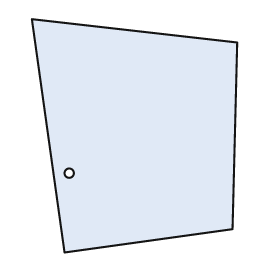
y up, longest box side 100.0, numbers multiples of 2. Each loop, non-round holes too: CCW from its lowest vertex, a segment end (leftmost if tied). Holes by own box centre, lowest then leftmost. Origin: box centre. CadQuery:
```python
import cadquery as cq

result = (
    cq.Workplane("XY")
    .moveTo(-30.0, -50.0)
    .lineTo(42.0, -40.0)
    .lineTo(44.0, 40.0)
    .lineTo(-44.0, 50.0)
    .close()
    .moveTo(-28.0, -16.0)
    .circle(2.0)
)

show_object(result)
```